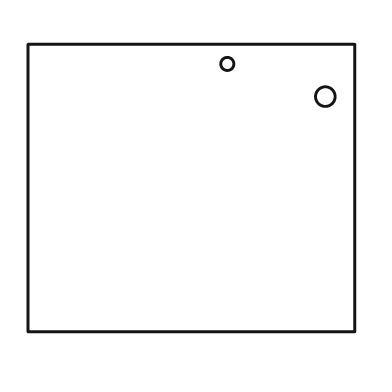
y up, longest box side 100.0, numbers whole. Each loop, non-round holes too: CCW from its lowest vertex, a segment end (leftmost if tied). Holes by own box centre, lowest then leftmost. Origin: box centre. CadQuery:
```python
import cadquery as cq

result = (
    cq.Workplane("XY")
    .moveTo(-50.0, -44.0)
    .lineTo(50.0, -44.0)
    .lineTo(50.0, 44.0)
    .lineTo(-50.0, 44.0)
    .close()
    .moveTo(41.0, 28.0)
    .circle(3.0)
    .moveTo(11.0, 38.0)
    .circle(2.0)
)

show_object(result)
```